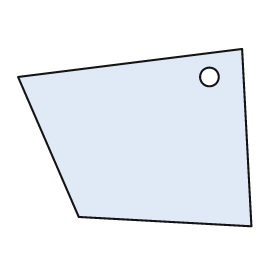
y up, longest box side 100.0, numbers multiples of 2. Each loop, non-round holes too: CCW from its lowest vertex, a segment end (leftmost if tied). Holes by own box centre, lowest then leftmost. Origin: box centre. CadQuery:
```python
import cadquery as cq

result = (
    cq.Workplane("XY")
    .moveTo(50.0, -38.0)
    .lineTo(46.0, 38.0)
    .lineTo(-50.0, 26.0)
    .lineTo(-24.0, -34.0)
    .close()
    .moveTo(32.0, 26.0)
    .circle(4.0)
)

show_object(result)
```